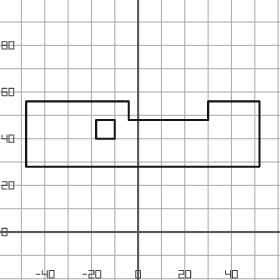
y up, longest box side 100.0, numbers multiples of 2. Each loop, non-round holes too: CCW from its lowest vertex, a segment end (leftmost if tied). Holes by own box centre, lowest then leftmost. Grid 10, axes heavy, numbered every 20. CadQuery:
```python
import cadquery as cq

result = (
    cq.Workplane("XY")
    .moveTo(-48.0, 28.0)
    .lineTo(52.0, 28.0)
    .lineTo(52.0, 56.0)
    .lineTo(30.0, 56.0)
    .lineTo(30.0, 48.0)
    .lineTo(-4.0, 48.0)
    .lineTo(-4.0, 56.0)
    .lineTo(-48.0, 56.0)
    .close()
    .moveTo(-18.0, 40.0)
    .lineTo(-10.0, 40.0)
    .lineTo(-10.0, 48.0)
    .lineTo(-18.0, 48.0)
    .close()
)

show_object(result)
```